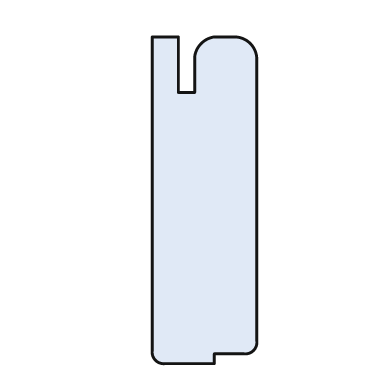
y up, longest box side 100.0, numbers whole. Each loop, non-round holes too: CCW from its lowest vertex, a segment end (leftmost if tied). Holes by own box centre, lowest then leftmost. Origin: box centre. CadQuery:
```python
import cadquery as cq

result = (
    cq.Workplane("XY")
    .moveTo(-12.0, -50.0)
    .lineTo(3.0, -50.0)
    .lineTo(3.0, -47.0)
    .lineTo(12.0, -47.0)
    .threePointArc((15.0, -46.0), (16.0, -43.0))
    .lineTo(16.0, 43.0)
    .threePointArc((14.0, 48.0), (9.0, 50.0))
    .lineTo(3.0, 50.0)
    .threePointArc((-1.0, 48.0), (-3.0, 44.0))
    .lineTo(-3.0, 33.0)
    .lineTo(-8.0, 33.0)
    .lineTo(-8.0, 50.0)
    .lineTo(-16.0, 50.0)
    .lineTo(-16.0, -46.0)
    .threePointArc((-15.0, -49.0), (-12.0, -50.0))
    .close()
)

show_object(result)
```